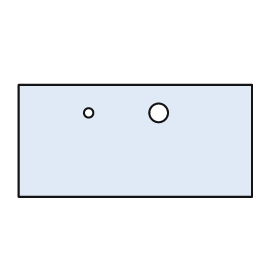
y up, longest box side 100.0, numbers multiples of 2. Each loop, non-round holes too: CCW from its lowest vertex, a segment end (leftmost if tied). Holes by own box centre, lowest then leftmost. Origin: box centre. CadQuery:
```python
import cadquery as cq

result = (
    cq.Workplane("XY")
    .moveTo(-50.0, -24.0)
    .lineTo(50.0, -24.0)
    .lineTo(50.0, 24.0)
    .lineTo(-50.0, 24.0)
    .close()
    .moveTo(-20.0, 12.0)
    .circle(2.0)
    .moveTo(10.0, 12.0)
    .circle(4.0)
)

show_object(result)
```